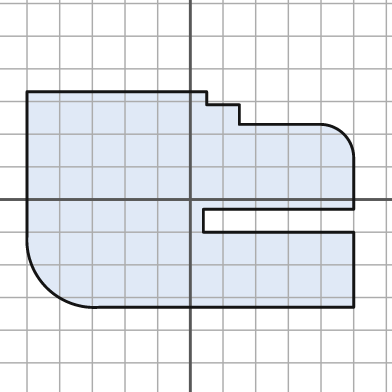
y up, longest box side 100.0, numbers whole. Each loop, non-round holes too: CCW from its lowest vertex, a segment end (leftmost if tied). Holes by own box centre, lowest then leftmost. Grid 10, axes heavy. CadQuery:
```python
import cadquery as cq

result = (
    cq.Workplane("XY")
    .moveTo(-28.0, -33.0)
    .lineTo(50.0, -33.0)
    .lineTo(50.0, -10.0)
    .lineTo(4.0, -10.0)
    .lineTo(4.0, -3.0)
    .lineTo(50.0, -3.0)
    .lineTo(50.0, 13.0)
    .threePointArc((47.0, 20.0), (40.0, 23.0))
    .lineTo(15.0, 23.0)
    .lineTo(15.0, 29.0)
    .lineTo(5.0, 29.0)
    .lineTo(5.0, 33.0)
    .lineTo(-50.0, 33.0)
    .lineTo(-50.0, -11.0)
    .threePointArc((-44.0, -27.0), (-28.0, -33.0))
    .close()
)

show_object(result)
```